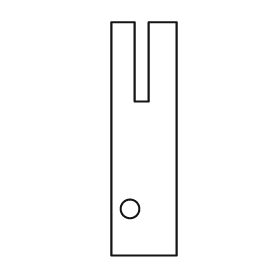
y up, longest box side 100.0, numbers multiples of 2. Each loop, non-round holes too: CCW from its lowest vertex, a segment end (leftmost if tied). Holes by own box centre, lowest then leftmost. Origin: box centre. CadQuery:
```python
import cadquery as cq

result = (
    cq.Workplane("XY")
    .moveTo(-14.0, -50.0)
    .lineTo(14.0, -50.0)
    .lineTo(14.0, 50.0)
    .lineTo(2.0, 50.0)
    .lineTo(2.0, 16.0)
    .lineTo(-4.0, 16.0)
    .lineTo(-4.0, 50.0)
    .lineTo(-14.0, 50.0)
    .close()
    .moveTo(-6.0, -30.0)
    .circle(4.0)
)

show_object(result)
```